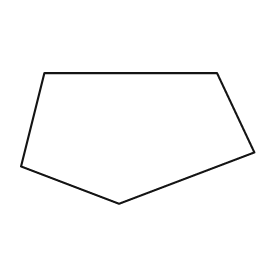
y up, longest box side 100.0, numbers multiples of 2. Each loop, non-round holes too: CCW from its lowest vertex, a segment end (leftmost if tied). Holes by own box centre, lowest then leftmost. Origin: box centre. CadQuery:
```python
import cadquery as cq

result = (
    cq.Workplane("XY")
    .moveTo(-8.0, -28.0)
    .lineTo(50.0, -6.0)
    .lineTo(34.0, 28.0)
    .lineTo(-40.0, 28.0)
    .lineTo(-50.0, -12.0)
    .close()
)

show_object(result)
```